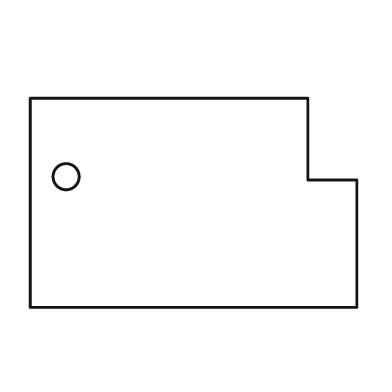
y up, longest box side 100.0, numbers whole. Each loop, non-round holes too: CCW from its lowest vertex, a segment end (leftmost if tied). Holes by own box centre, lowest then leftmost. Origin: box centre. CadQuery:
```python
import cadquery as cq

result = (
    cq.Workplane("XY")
    .moveTo(-50.0, -32.0)
    .lineTo(50.0, -32.0)
    .lineTo(50.0, 7.0)
    .lineTo(35.0, 7.0)
    .lineTo(35.0, 32.0)
    .lineTo(-50.0, 32.0)
    .close()
    .moveTo(-39.0, 8.0)
    .circle(4.0)
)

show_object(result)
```